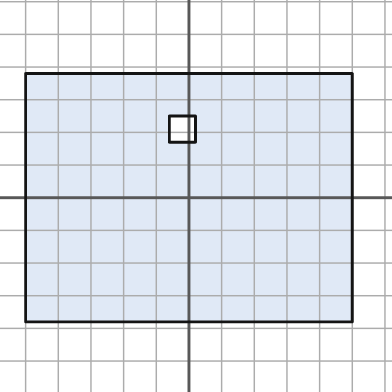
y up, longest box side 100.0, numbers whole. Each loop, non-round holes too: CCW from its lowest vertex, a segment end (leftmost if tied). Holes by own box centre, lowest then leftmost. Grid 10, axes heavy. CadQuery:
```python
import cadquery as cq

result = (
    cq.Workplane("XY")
    .moveTo(-50.0, -38.0)
    .lineTo(50.0, -38.0)
    .lineTo(50.0, 38.0)
    .lineTo(-50.0, 38.0)
    .close()
    .moveTo(-6.0, 17.0)
    .lineTo(2.0, 17.0)
    .lineTo(2.0, 25.0)
    .lineTo(-6.0, 25.0)
    .close()
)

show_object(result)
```